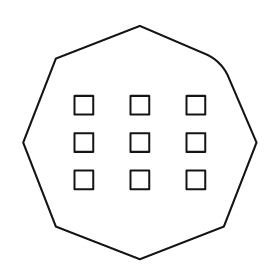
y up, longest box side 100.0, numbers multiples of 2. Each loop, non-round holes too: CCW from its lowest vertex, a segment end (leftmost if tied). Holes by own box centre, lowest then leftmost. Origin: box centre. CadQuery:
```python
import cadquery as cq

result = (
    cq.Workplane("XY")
    .moveTo(0.0, -50.0)
    .lineTo(36.0, -36.0)
    .lineTo(50.0, 0.0)
    .lineTo(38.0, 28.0)
    .threePointArc((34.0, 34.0), (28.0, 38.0))
    .lineTo(0.0, 50.0)
    .lineTo(-36.0, 36.0)
    .lineTo(-50.0, 0.0)
    .lineTo(-36.0, -36.0)
    .close()
    .moveTo(-28.0, -20.0)
    .lineTo(-20.0, -20.0)
    .lineTo(-20.0, -12.0)
    .lineTo(-28.0, -12.0)
    .close()
    .moveTo(-4.0, -20.0)
    .lineTo(4.0, -20.0)
    .lineTo(4.0, -12.0)
    .lineTo(-4.0, -12.0)
    .close()
    .moveTo(20.0, -20.0)
    .lineTo(28.0, -20.0)
    .lineTo(28.0, -12.0)
    .lineTo(20.0, -12.0)
    .close()
    .moveTo(-28.0, -4.0)
    .lineTo(-20.0, -4.0)
    .lineTo(-20.0, 4.0)
    .lineTo(-28.0, 4.0)
    .close()
    .moveTo(-4.0, -4.0)
    .lineTo(4.0, -4.0)
    .lineTo(4.0, 4.0)
    .lineTo(-4.0, 4.0)
    .close()
    .moveTo(20.0, -4.0)
    .lineTo(28.0, -4.0)
    .lineTo(28.0, 4.0)
    .lineTo(20.0, 4.0)
    .close()
    .moveTo(-28.0, 12.0)
    .lineTo(-20.0, 12.0)
    .lineTo(-20.0, 20.0)
    .lineTo(-28.0, 20.0)
    .close()
    .moveTo(-4.0, 12.0)
    .lineTo(4.0, 12.0)
    .lineTo(4.0, 20.0)
    .lineTo(-4.0, 20.0)
    .close()
    .moveTo(20.0, 12.0)
    .lineTo(28.0, 12.0)
    .lineTo(28.0, 20.0)
    .lineTo(20.0, 20.0)
    .close()
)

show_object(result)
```